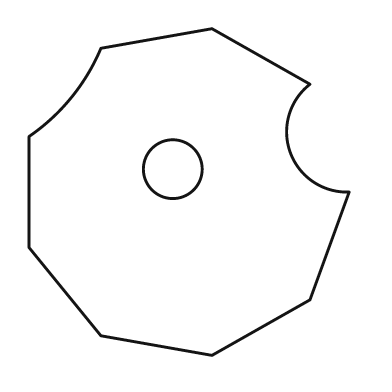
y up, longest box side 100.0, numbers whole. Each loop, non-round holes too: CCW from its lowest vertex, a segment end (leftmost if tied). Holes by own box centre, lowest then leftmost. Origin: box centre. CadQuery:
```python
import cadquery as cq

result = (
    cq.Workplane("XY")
    .moveTo(7.0, -50.0)
    .lineTo(37.0, -33.0)
    .lineTo(49.0, 0.0)
    .threePointArc((31.0, 12.0), (37.0, 33.0))
    .lineTo(7.0, 50.0)
    .lineTo(-27.0, 44.0)
    .threePointArc((-36.0, 29.0), (-49.0, 17.0))
    .lineTo(-49.0, -17.0)
    .lineTo(-27.0, -44.0)
    .close()
    .moveTo(-5.0, 7.0)
    .circle(9.0)
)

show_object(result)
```